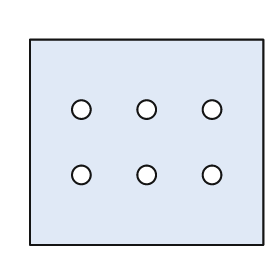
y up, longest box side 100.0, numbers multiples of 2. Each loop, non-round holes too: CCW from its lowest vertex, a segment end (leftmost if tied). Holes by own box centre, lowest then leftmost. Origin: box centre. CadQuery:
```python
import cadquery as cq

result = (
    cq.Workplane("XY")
    .moveTo(-50.0, -44.0)
    .lineTo(50.0, -44.0)
    .lineTo(50.0, 44.0)
    .lineTo(-50.0, 44.0)
    .close()
    .moveTo(-28.0, -14.0)
    .circle(4.0)
    .moveTo(0.0, -14.0)
    .circle(4.0)
    .moveTo(28.0, -14.0)
    .circle(4.0)
    .moveTo(-28.0, 14.0)
    .circle(4.0)
    .moveTo(0.0, 14.0)
    .circle(4.0)
    .moveTo(28.0, 14.0)
    .circle(4.0)
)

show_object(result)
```